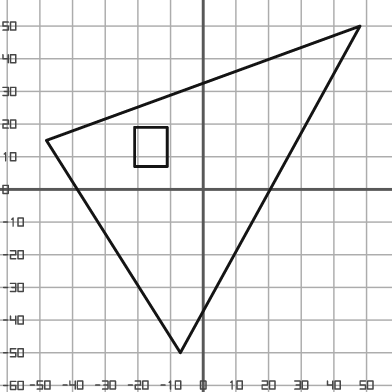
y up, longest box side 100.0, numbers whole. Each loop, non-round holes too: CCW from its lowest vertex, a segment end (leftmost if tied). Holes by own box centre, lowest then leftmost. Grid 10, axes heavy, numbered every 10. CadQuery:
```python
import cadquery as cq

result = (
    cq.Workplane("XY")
    .moveTo(-7.0, -50.0)
    .lineTo(48.0, 50.0)
    .lineTo(-48.0, 15.0)
    .close()
    .moveTo(-21.0, 7.0)
    .lineTo(-11.0, 7.0)
    .lineTo(-11.0, 19.0)
    .lineTo(-21.0, 19.0)
    .close()
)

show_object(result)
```